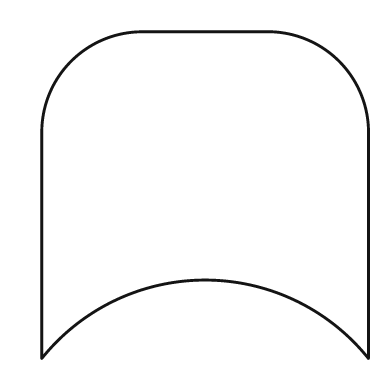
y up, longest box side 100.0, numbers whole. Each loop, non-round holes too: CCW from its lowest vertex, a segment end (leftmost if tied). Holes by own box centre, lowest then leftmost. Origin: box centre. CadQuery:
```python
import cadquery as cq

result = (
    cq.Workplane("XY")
    .moveTo(-50.0, -50.0)
    .threePointArc((0.0, -26.0), (50.0, -50.0))
    .lineTo(50.0, 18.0)
    .threePointArc((41.0, 41.0), (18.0, 50.0))
    .lineTo(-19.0, 50.0)
    .threePointArc((-41.0, 41.0), (-50.0, 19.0))
    .close()
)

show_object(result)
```